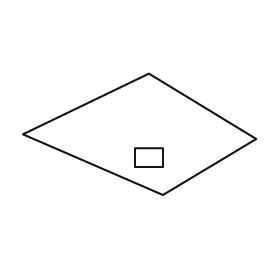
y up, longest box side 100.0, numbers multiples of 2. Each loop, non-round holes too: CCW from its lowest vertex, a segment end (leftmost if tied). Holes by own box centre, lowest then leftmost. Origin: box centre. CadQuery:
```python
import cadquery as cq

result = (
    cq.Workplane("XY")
    .moveTo(10.0, -26.0)
    .lineTo(50.0, -2.0)
    .lineTo(4.0, 26.0)
    .lineTo(-50.0, 0.0)
    .close()
    .moveTo(-2.0, -14.0)
    .lineTo(10.0, -14.0)
    .lineTo(10.0, -6.0)
    .lineTo(-2.0, -6.0)
    .close()
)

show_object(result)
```